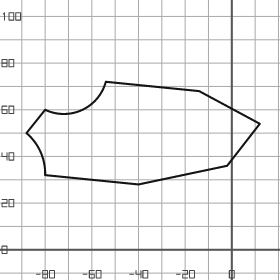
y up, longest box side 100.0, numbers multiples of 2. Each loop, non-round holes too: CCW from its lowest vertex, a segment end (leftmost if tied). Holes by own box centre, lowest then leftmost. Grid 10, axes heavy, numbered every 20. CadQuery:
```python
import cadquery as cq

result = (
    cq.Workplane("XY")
    .moveTo(-40.0, 28.0)
    .lineTo(-2.0, 36.0)
    .lineTo(12.0, 54.0)
    .lineTo(-14.0, 68.0)
    .lineTo(-54.0, 72.0)
    .threePointArc((-64.0, 60.0), (-80.0, 60.0))
    .lineTo(-88.0, 50.0)
    .threePointArc((-82.0, 42.0), (-80.0, 32.0))
    .close()
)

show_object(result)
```